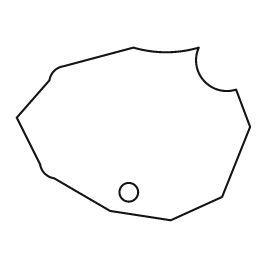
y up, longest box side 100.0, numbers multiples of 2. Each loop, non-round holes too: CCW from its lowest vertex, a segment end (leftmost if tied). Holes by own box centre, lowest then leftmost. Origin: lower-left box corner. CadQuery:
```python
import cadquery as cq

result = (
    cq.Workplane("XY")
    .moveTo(66.0, 0.0)
    .lineTo(88.0, 10.0)
    .lineTo(100.0, 40.0)
    .lineTo(94.0, 56.0)
    .threePointArc((80.0, 60.0), (78.0, 74.0))
    .threePointArc((64.0, 72.0), (50.0, 74.0))
    .lineTo(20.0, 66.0)
    .threePointArc((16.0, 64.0), (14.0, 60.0))
    .lineTo(0.0, 44.0)
    .lineTo(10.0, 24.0)
    .threePointArc((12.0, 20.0), (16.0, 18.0))
    .lineTo(40.0, 4.0)
    .close()
    .moveTo(48.0, 12.0)
    .circle(4.0)
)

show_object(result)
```